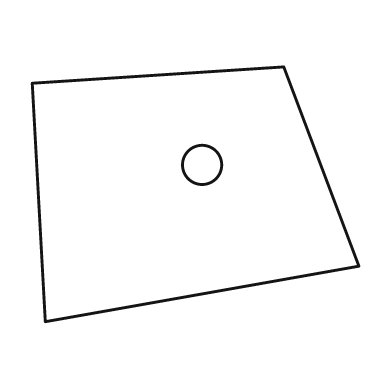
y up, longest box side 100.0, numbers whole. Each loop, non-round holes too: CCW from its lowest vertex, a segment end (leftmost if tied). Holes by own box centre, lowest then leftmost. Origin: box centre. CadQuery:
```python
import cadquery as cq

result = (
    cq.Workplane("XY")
    .moveTo(-46.0, -39.0)
    .lineTo(50.0, -22.0)
    .lineTo(27.0, 39.0)
    .lineTo(-50.0, 34.0)
    .close()
    .moveTo(2.0, 9.0)
    .circle(6.0)
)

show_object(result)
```